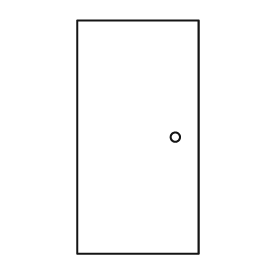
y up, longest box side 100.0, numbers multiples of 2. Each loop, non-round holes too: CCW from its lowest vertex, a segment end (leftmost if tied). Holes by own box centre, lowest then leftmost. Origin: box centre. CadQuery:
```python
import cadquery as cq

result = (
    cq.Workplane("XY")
    .moveTo(-26.0, -50.0)
    .lineTo(26.0, -50.0)
    .lineTo(26.0, 50.0)
    .lineTo(-26.0, 50.0)
    .close()
    .moveTo(16.0, 0.0)
    .circle(2.0)
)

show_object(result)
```